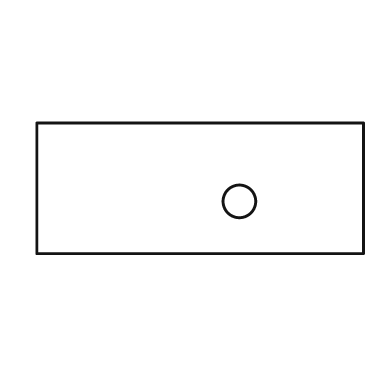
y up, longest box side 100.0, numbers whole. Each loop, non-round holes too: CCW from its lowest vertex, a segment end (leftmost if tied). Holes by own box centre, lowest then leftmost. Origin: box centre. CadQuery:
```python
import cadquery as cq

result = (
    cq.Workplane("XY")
    .moveTo(-50.0, -20.0)
    .lineTo(50.0, -20.0)
    .lineTo(50.0, 20.0)
    .lineTo(-50.0, 20.0)
    .close()
    .moveTo(12.0, -4.0)
    .circle(5.0)
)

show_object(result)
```